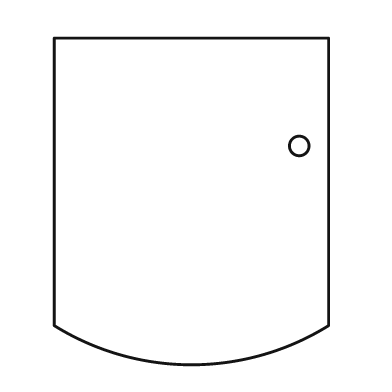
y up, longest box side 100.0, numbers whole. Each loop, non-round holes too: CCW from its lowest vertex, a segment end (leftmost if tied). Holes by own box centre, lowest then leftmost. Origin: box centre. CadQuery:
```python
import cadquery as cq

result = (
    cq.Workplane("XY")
    .moveTo(-42.0, -38.0)
    .threePointArc((0.0, -50.0), (42.0, -38.0))
    .lineTo(42.0, 50.0)
    .lineTo(-42.0, 50.0)
    .close()
    .moveTo(33.0, 17.0)
    .circle(3.0)
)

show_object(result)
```